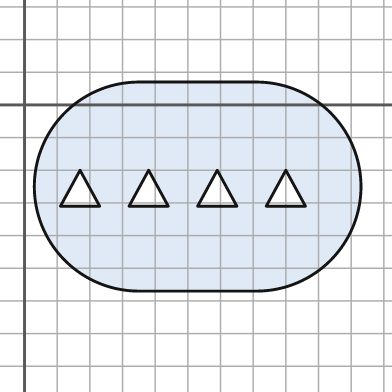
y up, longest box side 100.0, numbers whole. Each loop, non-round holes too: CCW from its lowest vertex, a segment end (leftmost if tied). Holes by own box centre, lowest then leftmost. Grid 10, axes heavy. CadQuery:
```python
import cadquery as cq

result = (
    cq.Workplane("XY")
    .moveTo(35.0, -57.0)
    .lineTo(71.0, -57.0)
    .threePointArc((103.0, -25.0), (71.0, 7.0))
    .lineTo(35.0, 7.0)
    .threePointArc((3.0, -25.0), (35.0, -57.0))
    .close()
    .moveTo(11.0, -31.0)
    .lineTo(23.0, -31.0)
    .lineTo(17.0, -20.0)
    .close()
    .moveTo(32.0, -31.0)
    .lineTo(44.0, -31.0)
    .lineTo(38.0, -20.0)
    .close()
    .moveTo(53.0, -31.0)
    .lineTo(65.0, -31.0)
    .lineTo(59.0, -20.0)
    .close()
    .moveTo(74.0, -31.0)
    .lineTo(86.0, -31.0)
    .lineTo(80.0, -20.0)
    .close()
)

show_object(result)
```